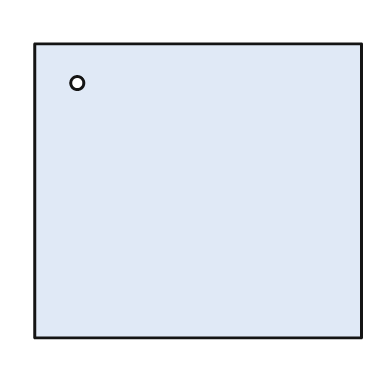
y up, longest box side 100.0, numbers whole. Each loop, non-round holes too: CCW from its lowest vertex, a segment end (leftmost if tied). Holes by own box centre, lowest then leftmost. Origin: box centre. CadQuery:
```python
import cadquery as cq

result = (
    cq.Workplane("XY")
    .moveTo(-50.0, -45.0)
    .lineTo(50.0, -45.0)
    .lineTo(50.0, 45.0)
    .lineTo(-50.0, 45.0)
    .close()
    .moveTo(-37.0, 33.0)
    .circle(2.0)
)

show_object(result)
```